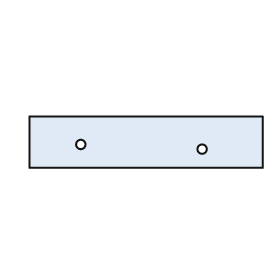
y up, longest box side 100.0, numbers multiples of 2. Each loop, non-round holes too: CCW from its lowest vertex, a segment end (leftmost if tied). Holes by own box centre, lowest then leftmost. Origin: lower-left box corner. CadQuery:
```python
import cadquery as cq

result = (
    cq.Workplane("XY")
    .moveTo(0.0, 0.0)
    .lineTo(100.0, 0.0)
    .lineTo(100.0, 22.0)
    .lineTo(0.0, 22.0)
    .close()
    .moveTo(74.0, 8.0)
    .circle(2.0)
    .moveTo(22.0, 10.0)
    .circle(2.0)
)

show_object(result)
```